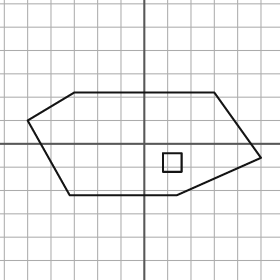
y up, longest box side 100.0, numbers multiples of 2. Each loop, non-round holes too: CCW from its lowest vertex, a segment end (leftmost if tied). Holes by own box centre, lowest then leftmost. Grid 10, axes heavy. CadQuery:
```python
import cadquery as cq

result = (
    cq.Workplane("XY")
    .moveTo(-32.0, -22.0)
    .lineTo(14.0, -22.0)
    .lineTo(50.0, -6.0)
    .lineTo(30.0, 22.0)
    .lineTo(-30.0, 22.0)
    .lineTo(-50.0, 10.0)
    .close()
    .moveTo(8.0, -12.0)
    .lineTo(16.0, -12.0)
    .lineTo(16.0, -4.0)
    .lineTo(8.0, -4.0)
    .close()
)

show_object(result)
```